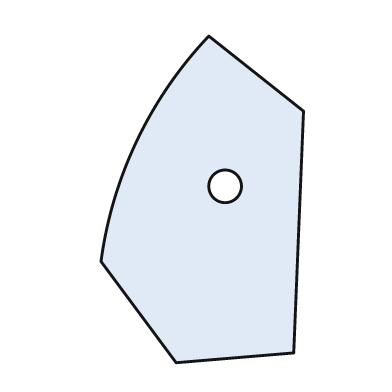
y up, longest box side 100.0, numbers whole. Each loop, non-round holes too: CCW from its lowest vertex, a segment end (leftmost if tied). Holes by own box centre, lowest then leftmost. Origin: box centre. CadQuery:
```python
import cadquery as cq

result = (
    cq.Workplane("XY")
    .moveTo(-8.0, -50.0)
    .lineTo(28.0, -47.0)
    .lineTo(31.0, 27.0)
    .lineTo(2.0, 50.0)
    .threePointArc((-20.0, 18.0), (-31.0, -19.0))
    .close()
    .moveTo(7.0, 4.0)
    .circle(5.0)
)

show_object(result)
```